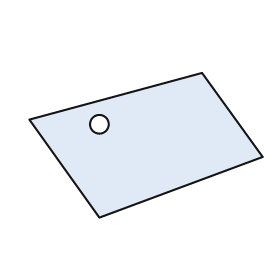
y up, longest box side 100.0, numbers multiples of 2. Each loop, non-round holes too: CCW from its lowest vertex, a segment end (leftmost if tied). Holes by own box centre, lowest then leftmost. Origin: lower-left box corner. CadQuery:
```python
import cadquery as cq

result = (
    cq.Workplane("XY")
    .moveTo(30.0, 0.0)
    .lineTo(100.0, 26.0)
    .lineTo(74.0, 62.0)
    .lineTo(0.0, 42.0)
    .close()
    .moveTo(30.0, 40.0)
    .circle(4.0)
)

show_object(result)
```